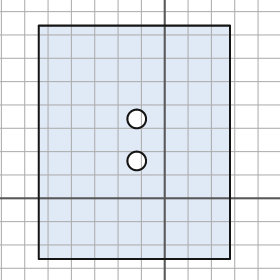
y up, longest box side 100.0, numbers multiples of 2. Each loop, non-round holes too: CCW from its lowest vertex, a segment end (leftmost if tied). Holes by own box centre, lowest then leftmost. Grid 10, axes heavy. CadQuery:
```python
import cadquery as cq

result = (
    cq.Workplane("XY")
    .moveTo(-54.0, -26.0)
    .lineTo(28.0, -26.0)
    .lineTo(28.0, 74.0)
    .lineTo(-54.0, 74.0)
    .close()
    .moveTo(-12.0, 16.0)
    .circle(4.0)
    .moveTo(-12.0, 34.0)
    .circle(4.0)
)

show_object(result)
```